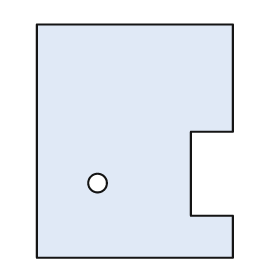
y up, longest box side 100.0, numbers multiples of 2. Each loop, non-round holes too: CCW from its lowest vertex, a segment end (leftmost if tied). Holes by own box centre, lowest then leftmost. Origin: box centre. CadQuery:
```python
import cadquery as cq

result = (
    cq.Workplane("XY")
    .moveTo(-42.0, -50.0)
    .lineTo(42.0, -50.0)
    .lineTo(42.0, -32.0)
    .lineTo(24.0, -32.0)
    .lineTo(24.0, 4.0)
    .lineTo(42.0, 4.0)
    .lineTo(42.0, 50.0)
    .lineTo(-42.0, 50.0)
    .close()
    .moveTo(-16.0, -18.0)
    .circle(4.0)
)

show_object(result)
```